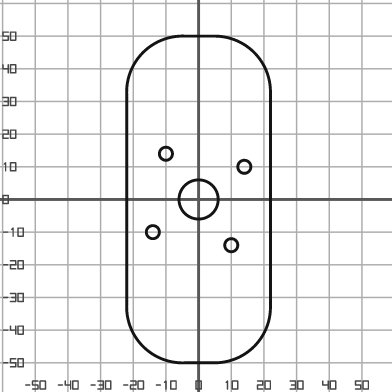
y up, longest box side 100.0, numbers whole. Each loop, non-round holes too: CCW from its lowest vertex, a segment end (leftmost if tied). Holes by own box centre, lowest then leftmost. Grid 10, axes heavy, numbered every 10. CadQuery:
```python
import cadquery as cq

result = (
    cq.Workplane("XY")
    .moveTo(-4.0, -50.0)
    .lineTo(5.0, -50.0)
    .threePointArc((17.0, -45.0), (22.0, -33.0))
    .lineTo(22.0, 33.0)
    .threePointArc((17.0, 45.0), (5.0, 50.0))
    .lineTo(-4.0, 50.0)
    .threePointArc((-17.0, 45.0), (-22.0, 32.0))
    .lineTo(-22.0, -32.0)
    .threePointArc((-17.0, -45.0), (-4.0, -50.0))
    .close()
    .moveTo(10.0, -14.0)
    .circle(2.0)
    .moveTo(-14.0, -10.0)
    .circle(2.0)
    .moveTo(0.0, 0.0)
    .circle(6.0)
    .moveTo(14.0, 10.0)
    .circle(2.0)
    .moveTo(-10.0, 14.0)
    .circle(2.0)
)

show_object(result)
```